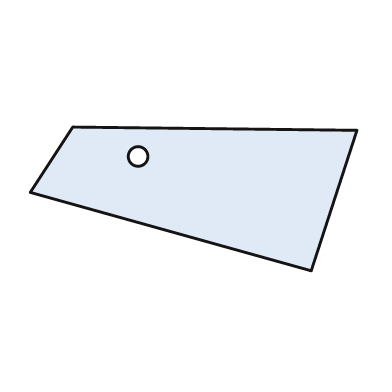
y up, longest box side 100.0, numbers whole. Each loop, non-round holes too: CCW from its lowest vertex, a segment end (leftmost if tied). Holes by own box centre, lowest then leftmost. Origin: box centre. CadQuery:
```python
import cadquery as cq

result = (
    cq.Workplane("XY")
    .moveTo(36.0, -22.0)
    .lineTo(50.0, 21.0)
    .lineTo(-37.0, 22.0)
    .lineTo(-50.0, 2.0)
    .close()
    .moveTo(-17.0, 13.0)
    .circle(3.0)
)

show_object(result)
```